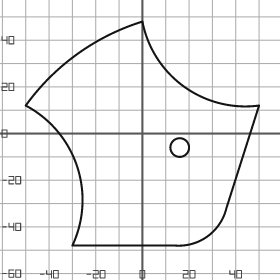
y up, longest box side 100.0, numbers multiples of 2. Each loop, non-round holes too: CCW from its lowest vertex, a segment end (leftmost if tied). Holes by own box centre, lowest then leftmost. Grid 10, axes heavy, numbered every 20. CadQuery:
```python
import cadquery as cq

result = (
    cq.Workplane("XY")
    .moveTo(-30.0, -48.0)
    .lineTo(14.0, -48.0)
    .threePointArc((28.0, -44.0), (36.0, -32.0))
    .lineTo(50.0, 12.0)
    .threePointArc((18.0, 20.0), (0.0, 48.0))
    .threePointArc((-28.0, 34.0), (-50.0, 12.0))
    .threePointArc((-28.0, -14.0), (-30.0, -48.0))
    .close()
    .moveTo(16.0, -6.0)
    .circle(4.0)
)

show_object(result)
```